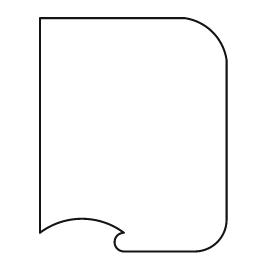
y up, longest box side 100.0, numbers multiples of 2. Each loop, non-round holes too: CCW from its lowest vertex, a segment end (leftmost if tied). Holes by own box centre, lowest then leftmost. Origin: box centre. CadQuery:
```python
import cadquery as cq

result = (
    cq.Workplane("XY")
    .moveTo(-4.0, -50.0)
    .lineTo(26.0, -50.0)
    .threePointArc((36.0, -46.0), (40.0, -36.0))
    .lineTo(40.0, 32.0)
    .threePointArc((34.0, 44.0), (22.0, 50.0))
    .lineTo(-40.0, 50.0)
    .lineTo(-40.0, -42.0)
    .threePointArc((-22.0, -36.0), (-4.0, -42.0))
    .threePointArc((-8.0, -46.0), (-4.0, -50.0))
    .close()
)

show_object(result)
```